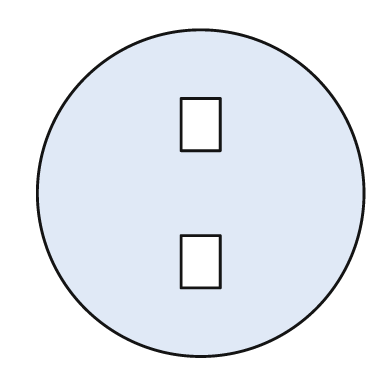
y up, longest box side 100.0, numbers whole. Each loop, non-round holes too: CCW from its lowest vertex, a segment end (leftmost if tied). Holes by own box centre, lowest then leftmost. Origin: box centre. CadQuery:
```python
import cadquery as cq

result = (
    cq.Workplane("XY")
    .moveTo(0.0, 0.0)
    .circle(50.0)
    .moveTo(-6.0, -29.0)
    .lineTo(6.0, -29.0)
    .lineTo(6.0, -13.0)
    .lineTo(-6.0, -13.0)
    .close()
    .moveTo(-6.0, 13.0)
    .lineTo(6.0, 13.0)
    .lineTo(6.0, 29.0)
    .lineTo(-6.0, 29.0)
    .close()
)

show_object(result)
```